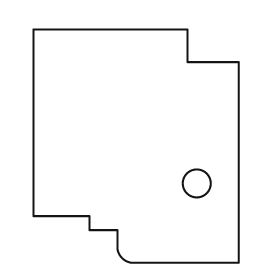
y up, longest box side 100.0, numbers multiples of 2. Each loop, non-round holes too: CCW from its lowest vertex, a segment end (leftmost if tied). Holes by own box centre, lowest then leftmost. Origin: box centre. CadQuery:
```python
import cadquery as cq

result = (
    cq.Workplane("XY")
    .moveTo(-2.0, -50.0)
    .lineTo(44.0, -50.0)
    .lineTo(44.0, 36.0)
    .lineTo(22.0, 36.0)
    .lineTo(22.0, 50.0)
    .lineTo(-44.0, 50.0)
    .lineTo(-44.0, -30.0)
    .lineTo(-20.0, -30.0)
    .lineTo(-20.0, -36.0)
    .lineTo(-8.0, -36.0)
    .lineTo(-8.0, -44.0)
    .threePointArc((-6.0, -48.0), (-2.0, -50.0))
    .close()
    .moveTo(26.0, -16.0)
    .circle(6.0)
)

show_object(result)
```